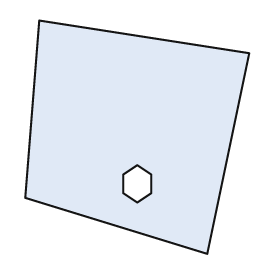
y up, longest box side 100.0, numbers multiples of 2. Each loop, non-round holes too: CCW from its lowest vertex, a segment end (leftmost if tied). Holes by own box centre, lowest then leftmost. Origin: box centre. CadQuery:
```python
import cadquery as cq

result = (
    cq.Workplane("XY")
    .moveTo(30.0, -50.0)
    .lineTo(48.0, 36.0)
    .lineTo(-42.0, 50.0)
    .lineTo(-48.0, -26.0)
    .close()
    .moveTo(0.0, -28.0)
    .lineTo(6.0, -24.0)
    .lineTo(6.0, -16.0)
    .lineTo(0.0, -12.0)
    .lineTo(-6.0, -16.0)
    .lineTo(-6.0, -24.0)
    .close()
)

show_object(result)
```